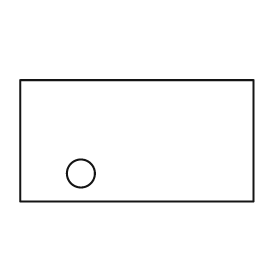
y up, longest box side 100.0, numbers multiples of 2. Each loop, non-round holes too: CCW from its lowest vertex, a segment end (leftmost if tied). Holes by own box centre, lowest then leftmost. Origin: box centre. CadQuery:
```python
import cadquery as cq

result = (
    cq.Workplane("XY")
    .moveTo(-50.0, -26.0)
    .lineTo(50.0, -26.0)
    .lineTo(50.0, 26.0)
    .lineTo(-50.0, 26.0)
    .close()
    .moveTo(-24.0, -14.0)
    .circle(6.0)
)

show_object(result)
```